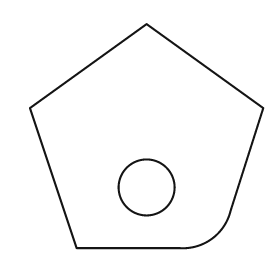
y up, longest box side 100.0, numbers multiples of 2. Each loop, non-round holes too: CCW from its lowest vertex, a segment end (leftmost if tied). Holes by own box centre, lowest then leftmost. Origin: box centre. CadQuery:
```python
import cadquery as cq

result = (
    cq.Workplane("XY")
    .moveTo(-30.0, -48.0)
    .lineTo(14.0, -48.0)
    .threePointArc((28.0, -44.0), (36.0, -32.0))
    .lineTo(50.0, 12.0)
    .lineTo(0.0, 48.0)
    .lineTo(-50.0, 12.0)
    .close()
    .moveTo(0.0, -22.0)
    .circle(12.0)
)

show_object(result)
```